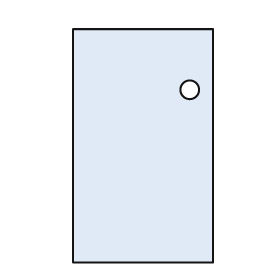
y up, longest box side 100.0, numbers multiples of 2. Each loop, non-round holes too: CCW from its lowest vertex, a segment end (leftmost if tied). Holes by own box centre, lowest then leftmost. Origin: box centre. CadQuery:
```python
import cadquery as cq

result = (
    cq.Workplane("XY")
    .moveTo(-30.0, -50.0)
    .lineTo(30.0, -50.0)
    .lineTo(30.0, 50.0)
    .lineTo(-30.0, 50.0)
    .close()
    .moveTo(20.0, 24.0)
    .circle(4.0)
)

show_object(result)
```